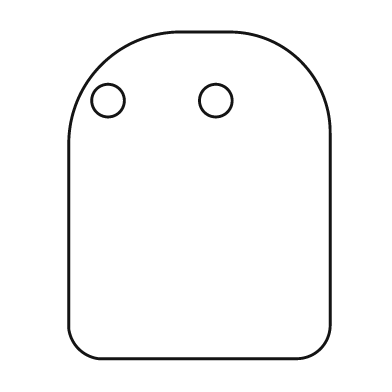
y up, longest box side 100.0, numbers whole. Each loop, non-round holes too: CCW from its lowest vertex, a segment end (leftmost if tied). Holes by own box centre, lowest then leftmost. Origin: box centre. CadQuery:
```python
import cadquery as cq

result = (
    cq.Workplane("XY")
    .moveTo(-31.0, -50.0)
    .lineTo(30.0, -50.0)
    .threePointArc((37.0, -47.0), (40.0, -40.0))
    .lineTo(40.0, 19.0)
    .threePointArc((31.0, 41.0), (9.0, 50.0))
    .lineTo(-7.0, 50.0)
    .threePointArc((-30.0, 40.0), (-40.0, 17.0))
    .lineTo(-40.0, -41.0)
    .threePointArc((-37.0, -47.0), (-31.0, -50.0))
    .close()
    .moveTo(-28.0, 29.0)
    .circle(5.0)
    .moveTo(5.0, 29.0)
    .circle(5.0)
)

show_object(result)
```